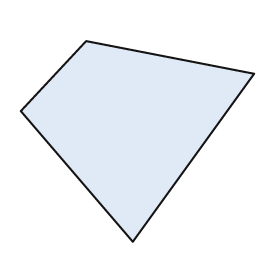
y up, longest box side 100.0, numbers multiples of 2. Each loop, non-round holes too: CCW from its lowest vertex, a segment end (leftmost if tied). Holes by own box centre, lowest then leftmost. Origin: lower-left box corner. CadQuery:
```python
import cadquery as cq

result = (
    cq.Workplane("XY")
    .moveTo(48.0, 0.0)
    .lineTo(100.0, 72.0)
    .lineTo(28.0, 86.0)
    .lineTo(0.0, 56.0)
    .close()
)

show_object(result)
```